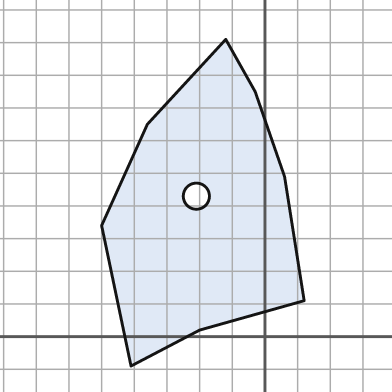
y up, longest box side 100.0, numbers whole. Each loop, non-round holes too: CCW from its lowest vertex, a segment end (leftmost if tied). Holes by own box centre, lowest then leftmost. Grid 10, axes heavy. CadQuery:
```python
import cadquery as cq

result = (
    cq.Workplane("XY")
    .moveTo(-41.0, -9.0)
    .lineTo(-20.0, 2.0)
    .lineTo(12.0, 11.0)
    .lineTo(6.0, 49.0)
    .lineTo(-3.0, 75.0)
    .lineTo(-12.0, 91.0)
    .lineTo(-36.0, 65.0)
    .lineTo(-50.0, 34.0)
    .close()
    .moveTo(-21.0, 43.0)
    .circle(4.0)
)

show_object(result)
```